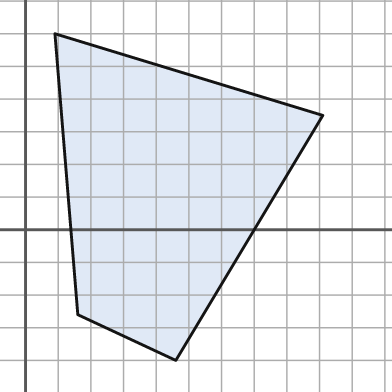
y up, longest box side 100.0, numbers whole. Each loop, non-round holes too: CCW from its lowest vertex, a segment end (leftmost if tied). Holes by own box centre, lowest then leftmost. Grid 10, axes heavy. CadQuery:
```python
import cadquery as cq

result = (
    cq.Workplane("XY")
    .moveTo(46.0, -40.0)
    .lineTo(91.0, 35.0)
    .lineTo(9.0, 60.0)
    .lineTo(16.0, -26.0)
    .close()
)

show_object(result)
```